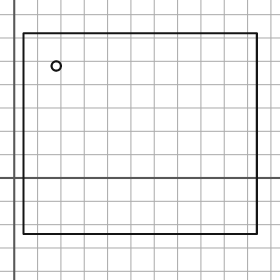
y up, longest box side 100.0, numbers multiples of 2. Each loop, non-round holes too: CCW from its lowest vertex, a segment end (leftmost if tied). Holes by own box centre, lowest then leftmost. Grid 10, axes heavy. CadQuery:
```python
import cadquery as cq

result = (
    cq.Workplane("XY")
    .moveTo(4.0, -24.0)
    .lineTo(104.0, -24.0)
    .lineTo(104.0, 62.0)
    .lineTo(4.0, 62.0)
    .close()
    .moveTo(18.0, 48.0)
    .circle(2.0)
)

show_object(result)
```